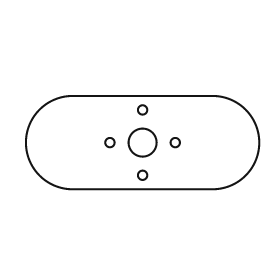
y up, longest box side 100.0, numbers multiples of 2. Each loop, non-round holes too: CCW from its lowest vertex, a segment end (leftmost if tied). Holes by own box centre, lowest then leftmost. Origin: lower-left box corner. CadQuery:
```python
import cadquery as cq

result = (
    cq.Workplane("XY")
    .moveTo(20.0, 0.0)
    .lineTo(80.0, 0.0)
    .threePointArc((100.0, 20.0), (80.0, 40.0))
    .lineTo(20.0, 40.0)
    .threePointArc((0.0, 20.0), (20.0, 0.0))
    .close()
    .moveTo(50.0, 6.0)
    .circle(2.0)
    .moveTo(36.0, 20.0)
    .circle(2.0)
    .moveTo(50.0, 20.0)
    .circle(6.0)
    .moveTo(64.0, 20.0)
    .circle(2.0)
    .moveTo(50.0, 34.0)
    .circle(2.0)
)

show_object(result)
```